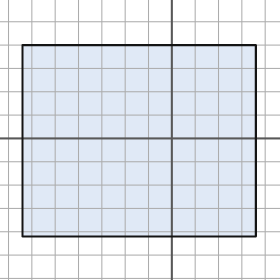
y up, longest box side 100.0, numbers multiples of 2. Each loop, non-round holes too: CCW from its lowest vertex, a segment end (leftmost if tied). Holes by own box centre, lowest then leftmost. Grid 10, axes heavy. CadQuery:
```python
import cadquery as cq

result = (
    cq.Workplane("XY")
    .moveTo(-64.0, -42.0)
    .lineTo(36.0, -42.0)
    .lineTo(36.0, 40.0)
    .lineTo(-64.0, 40.0)
    .close()
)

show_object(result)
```